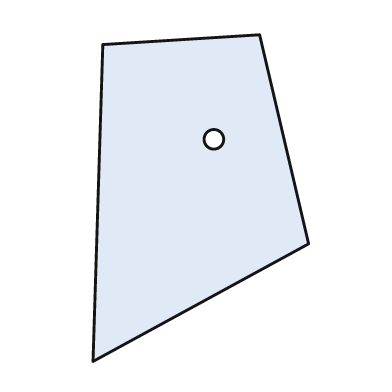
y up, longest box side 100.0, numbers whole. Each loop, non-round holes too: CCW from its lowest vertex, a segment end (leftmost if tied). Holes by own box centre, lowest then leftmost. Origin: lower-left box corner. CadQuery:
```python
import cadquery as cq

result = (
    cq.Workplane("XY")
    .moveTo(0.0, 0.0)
    .lineTo(66.0, 36.0)
    .lineTo(51.0, 100.0)
    .lineTo(3.0, 97.0)
    .close()
    .moveTo(37.0, 68.0)
    .circle(3.0)
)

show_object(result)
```